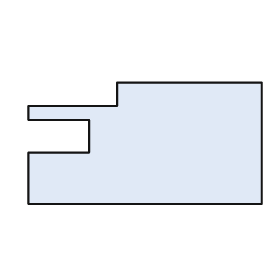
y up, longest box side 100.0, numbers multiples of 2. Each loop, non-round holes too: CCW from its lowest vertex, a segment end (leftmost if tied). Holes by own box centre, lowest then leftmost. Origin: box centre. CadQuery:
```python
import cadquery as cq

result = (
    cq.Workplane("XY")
    .moveTo(-50.0, -26.0)
    .lineTo(50.0, -26.0)
    .lineTo(50.0, 26.0)
    .lineTo(-12.0, 26.0)
    .lineTo(-12.0, 16.0)
    .lineTo(-50.0, 16.0)
    .lineTo(-50.0, 10.0)
    .lineTo(-24.0, 10.0)
    .lineTo(-24.0, -4.0)
    .lineTo(-50.0, -4.0)
    .close()
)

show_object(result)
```